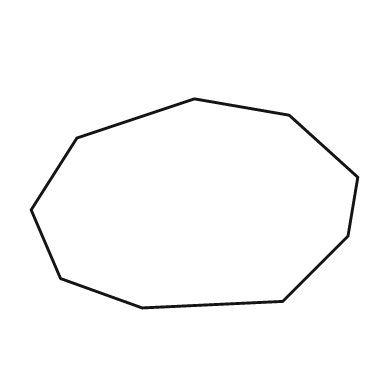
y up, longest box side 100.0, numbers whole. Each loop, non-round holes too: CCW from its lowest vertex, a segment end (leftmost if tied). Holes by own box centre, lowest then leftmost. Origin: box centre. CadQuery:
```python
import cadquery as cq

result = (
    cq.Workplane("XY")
    .moveTo(-16.0, -32.0)
    .lineTo(27.0, -30.0)
    .lineTo(47.0, -10.0)
    .lineTo(50.0, 8.0)
    .lineTo(29.0, 27.0)
    .lineTo(0.0, 32.0)
    .lineTo(-36.0, 20.0)
    .lineTo(-50.0, -2.0)
    .lineTo(-41.0, -23.0)
    .close()
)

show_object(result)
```